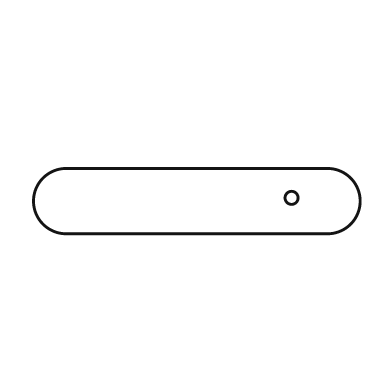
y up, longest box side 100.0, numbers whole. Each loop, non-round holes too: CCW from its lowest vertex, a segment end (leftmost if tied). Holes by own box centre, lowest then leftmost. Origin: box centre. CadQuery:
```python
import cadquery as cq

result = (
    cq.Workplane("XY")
    .moveTo(-40.0, -10.0)
    .lineTo(40.0, -10.0)
    .threePointArc((50.0, 0.0), (40.0, 10.0))
    .lineTo(-40.0, 10.0)
    .threePointArc((-50.0, 0.0), (-40.0, -10.0))
    .close()
    .moveTo(29.0, 1.0)
    .circle(2.0)
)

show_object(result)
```